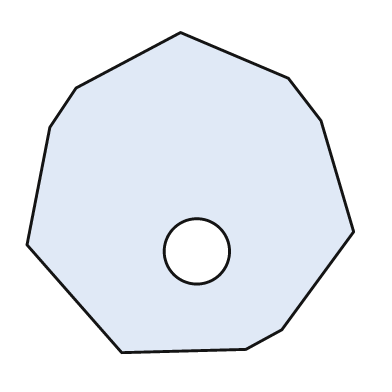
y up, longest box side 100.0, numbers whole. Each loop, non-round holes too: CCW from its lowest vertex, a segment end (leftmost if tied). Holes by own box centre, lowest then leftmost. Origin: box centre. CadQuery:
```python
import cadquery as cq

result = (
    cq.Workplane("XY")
    .moveTo(-21.0, -49.0)
    .lineTo(17.0, -48.0)
    .lineTo(28.0, -42.0)
    .lineTo(50.0, -12.0)
    .lineTo(40.0, 22.0)
    .lineTo(30.0, 35.0)
    .lineTo(-3.0, 49.0)
    .lineTo(-35.0, 32.0)
    .lineTo(-43.0, 20.0)
    .lineTo(-50.0, -16.0)
    .close()
    .moveTo(2.0, -18.0)
    .circle(10.0)
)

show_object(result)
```